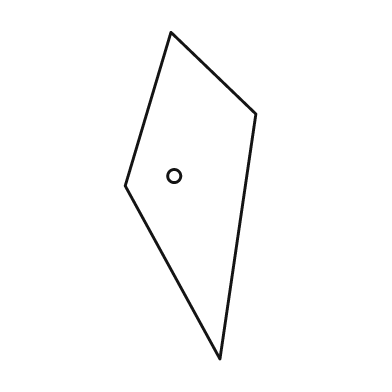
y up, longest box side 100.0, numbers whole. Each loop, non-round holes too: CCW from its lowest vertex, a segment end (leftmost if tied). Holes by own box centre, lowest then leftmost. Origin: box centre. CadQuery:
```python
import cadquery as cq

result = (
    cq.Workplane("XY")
    .moveTo(9.0, -50.0)
    .lineTo(20.0, 25.0)
    .lineTo(-6.0, 50.0)
    .lineTo(-20.0, 3.0)
    .close()
    .moveTo(-5.0, 6.0)
    .circle(2.0)
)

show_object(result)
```